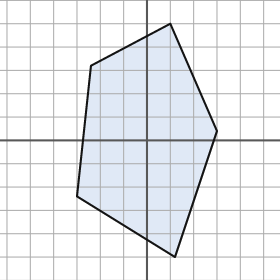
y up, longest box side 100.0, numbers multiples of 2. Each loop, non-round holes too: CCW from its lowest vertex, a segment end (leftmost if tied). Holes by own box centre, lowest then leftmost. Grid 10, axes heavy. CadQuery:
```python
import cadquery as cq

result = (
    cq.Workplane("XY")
    .moveTo(12.0, -50.0)
    .lineTo(30.0, 4.0)
    .lineTo(10.0, 50.0)
    .lineTo(-24.0, 32.0)
    .lineTo(-30.0, -24.0)
    .close()
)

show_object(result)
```